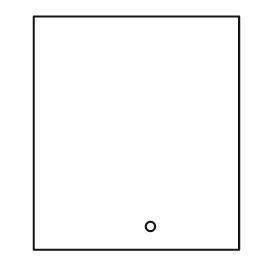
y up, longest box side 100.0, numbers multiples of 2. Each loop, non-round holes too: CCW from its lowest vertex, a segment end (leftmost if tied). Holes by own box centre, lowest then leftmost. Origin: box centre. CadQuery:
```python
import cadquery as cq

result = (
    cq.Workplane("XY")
    .moveTo(-44.0, -50.0)
    .lineTo(44.0, -50.0)
    .lineTo(44.0, 50.0)
    .lineTo(-44.0, 50.0)
    .close()
    .moveTo(6.0, -40.0)
    .circle(2.0)
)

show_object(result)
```